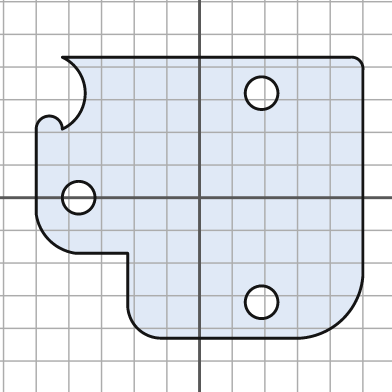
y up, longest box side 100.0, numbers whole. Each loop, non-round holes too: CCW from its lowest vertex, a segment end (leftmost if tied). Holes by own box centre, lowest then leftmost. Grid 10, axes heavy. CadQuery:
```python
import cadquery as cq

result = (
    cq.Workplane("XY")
    .moveTo(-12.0, -43.0)
    .lineTo(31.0, -43.0)
    .threePointArc((44.0, -37.0), (50.0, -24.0))
    .lineTo(50.0, 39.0)
    .threePointArc((49.0, 42.0), (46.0, 43.0))
    .lineTo(-42.0, 43.0)
    .threePointArc((-35.0, 32.0), (-42.0, 21.0))
    .threePointArc((-46.0, 25.0), (-50.0, 21.0))
    .lineTo(-50.0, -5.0)
    .threePointArc((-46.0, -13.0), (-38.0, -17.0))
    .lineTo(-22.0, -17.0)
    .lineTo(-22.0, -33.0)
    .threePointArc((-19.0, -40.0), (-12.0, -43.0))
    .close()
    .moveTo(19.0, -32.0)
    .circle(5.0)
    .moveTo(-37.0, 0.0)
    .circle(5.0)
    .moveTo(19.0, 32.0)
    .circle(5.0)
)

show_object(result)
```